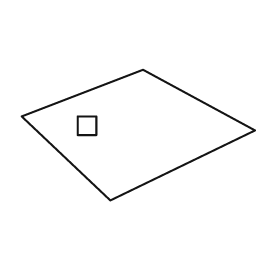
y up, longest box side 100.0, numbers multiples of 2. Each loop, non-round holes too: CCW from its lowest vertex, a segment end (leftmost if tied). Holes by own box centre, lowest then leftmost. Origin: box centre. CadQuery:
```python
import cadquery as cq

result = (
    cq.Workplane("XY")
    .moveTo(-12.0, -28.0)
    .lineTo(50.0, 2.0)
    .lineTo(2.0, 28.0)
    .lineTo(-50.0, 8.0)
    .close()
    .moveTo(-26.0, 0.0)
    .lineTo(-18.0, 0.0)
    .lineTo(-18.0, 8.0)
    .lineTo(-26.0, 8.0)
    .close()
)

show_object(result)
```